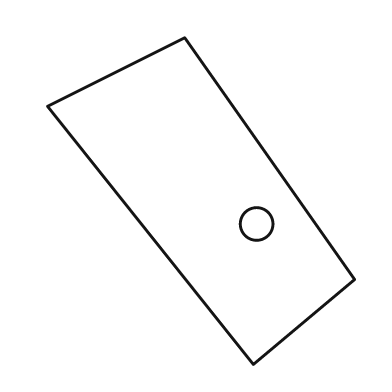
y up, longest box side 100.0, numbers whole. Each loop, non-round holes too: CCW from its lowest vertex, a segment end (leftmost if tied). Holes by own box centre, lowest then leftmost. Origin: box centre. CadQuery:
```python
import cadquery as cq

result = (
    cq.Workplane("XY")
    .moveTo(16.0, -50.0)
    .lineTo(47.0, -24.0)
    .lineTo(-5.0, 50.0)
    .lineTo(-47.0, 29.0)
    .close()
    .moveTo(17.0, -7.0)
    .circle(5.0)
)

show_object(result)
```